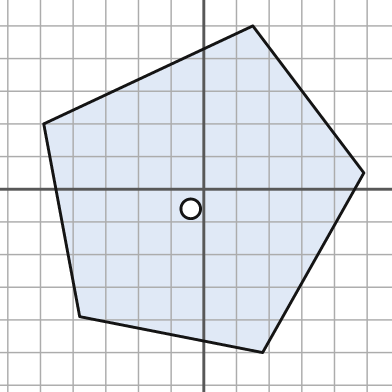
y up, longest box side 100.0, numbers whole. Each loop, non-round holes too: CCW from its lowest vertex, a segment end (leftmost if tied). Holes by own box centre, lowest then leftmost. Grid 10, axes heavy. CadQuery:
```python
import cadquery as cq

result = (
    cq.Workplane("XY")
    .moveTo(18.0, -50.0)
    .lineTo(49.0, 5.0)
    .lineTo(15.0, 50.0)
    .lineTo(-49.0, 20.0)
    .lineTo(-38.0, -39.0)
    .close()
    .moveTo(-4.0, -6.0)
    .circle(3.0)
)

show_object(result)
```